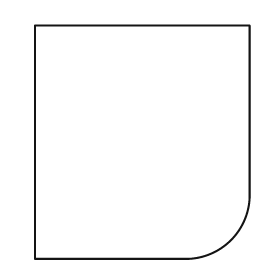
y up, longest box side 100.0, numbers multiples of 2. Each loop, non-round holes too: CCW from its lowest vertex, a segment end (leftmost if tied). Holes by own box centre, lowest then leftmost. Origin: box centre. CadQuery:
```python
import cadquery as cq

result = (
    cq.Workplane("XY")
    .moveTo(-46.0, -50.0)
    .lineTo(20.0, -50.0)
    .threePointArc((38.0, -42.0), (46.0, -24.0))
    .lineTo(46.0, 50.0)
    .lineTo(-46.0, 50.0)
    .close()
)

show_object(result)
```